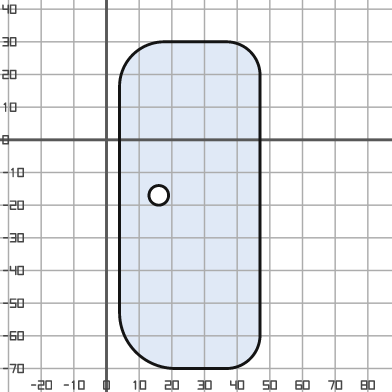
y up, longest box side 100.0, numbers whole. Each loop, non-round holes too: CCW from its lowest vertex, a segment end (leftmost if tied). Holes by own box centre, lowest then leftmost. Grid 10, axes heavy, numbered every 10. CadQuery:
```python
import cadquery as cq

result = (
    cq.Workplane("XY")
    .moveTo(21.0, -70.0)
    .lineTo(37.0, -70.0)
    .threePointArc((44.0, -67.0), (47.0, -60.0))
    .lineTo(47.0, 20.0)
    .threePointArc((44.0, 27.0), (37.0, 30.0))
    .lineTo(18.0, 30.0)
    .threePointArc((8.0, 26.0), (4.0, 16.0))
    .lineTo(4.0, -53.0)
    .threePointArc((9.0, -65.0), (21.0, -70.0))
    .close()
    .moveTo(16.0, -17.0)
    .circle(3.0)
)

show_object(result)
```